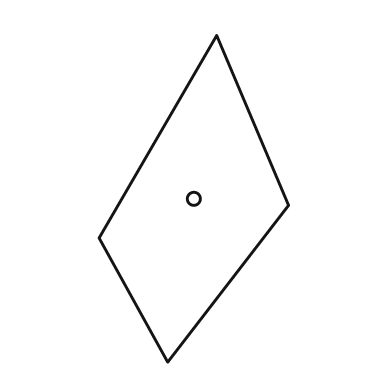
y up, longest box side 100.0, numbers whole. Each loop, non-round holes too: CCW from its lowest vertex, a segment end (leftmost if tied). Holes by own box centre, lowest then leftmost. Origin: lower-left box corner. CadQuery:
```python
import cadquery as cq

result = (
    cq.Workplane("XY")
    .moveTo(21.0, 0.0)
    .lineTo(58.0, 48.0)
    .lineTo(36.0, 100.0)
    .lineTo(0.0, 38.0)
    .close()
    .moveTo(29.0, 50.0)
    .circle(2.0)
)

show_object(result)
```